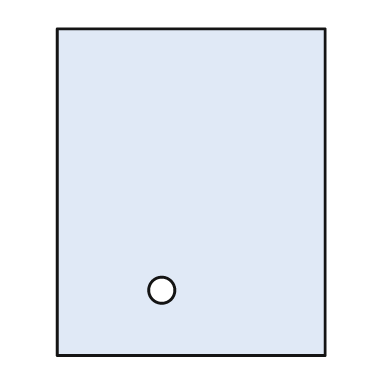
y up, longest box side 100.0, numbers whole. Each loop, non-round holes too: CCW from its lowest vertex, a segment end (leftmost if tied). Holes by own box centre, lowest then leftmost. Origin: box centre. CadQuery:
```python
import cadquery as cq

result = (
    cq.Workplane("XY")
    .moveTo(-41.0, -50.0)
    .lineTo(41.0, -50.0)
    .lineTo(41.0, 50.0)
    .lineTo(-41.0, 50.0)
    .close()
    .moveTo(-9.0, -30.0)
    .circle(4.0)
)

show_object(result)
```